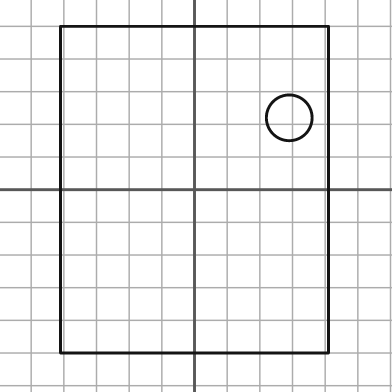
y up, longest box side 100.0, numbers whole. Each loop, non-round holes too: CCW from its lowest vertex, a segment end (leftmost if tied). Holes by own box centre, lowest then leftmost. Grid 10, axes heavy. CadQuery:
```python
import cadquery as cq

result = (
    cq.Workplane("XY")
    .moveTo(-41.0, -50.0)
    .lineTo(41.0, -50.0)
    .lineTo(41.0, 50.0)
    .lineTo(-41.0, 50.0)
    .close()
    .moveTo(29.0, 22.0)
    .circle(7.0)
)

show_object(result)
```